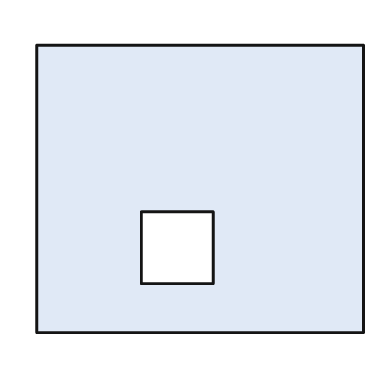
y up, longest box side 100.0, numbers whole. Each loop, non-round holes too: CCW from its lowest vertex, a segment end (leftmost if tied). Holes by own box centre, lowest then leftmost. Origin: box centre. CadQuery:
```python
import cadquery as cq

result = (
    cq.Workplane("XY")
    .moveTo(-50.0, -44.0)
    .lineTo(50.0, -44.0)
    .lineTo(50.0, 44.0)
    .lineTo(-50.0, 44.0)
    .close()
    .moveTo(-18.0, -29.0)
    .lineTo(4.0, -29.0)
    .lineTo(4.0, -7.0)
    .lineTo(-18.0, -7.0)
    .close()
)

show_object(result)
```